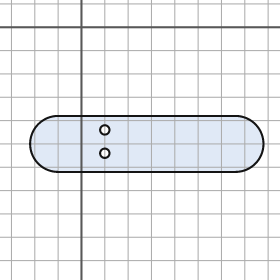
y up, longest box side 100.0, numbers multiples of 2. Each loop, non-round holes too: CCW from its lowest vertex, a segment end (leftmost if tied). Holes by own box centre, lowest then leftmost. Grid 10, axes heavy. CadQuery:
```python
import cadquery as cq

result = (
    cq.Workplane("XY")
    .moveTo(-10.0, -62.0)
    .lineTo(66.0, -62.0)
    .threePointArc((78.0, -50.0), (66.0, -38.0))
    .lineTo(-10.0, -38.0)
    .threePointArc((-22.0, -50.0), (-10.0, -62.0))
    .close()
    .moveTo(10.0, -54.0)
    .circle(2.0)
    .moveTo(10.0, -44.0)
    .circle(2.0)
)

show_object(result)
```